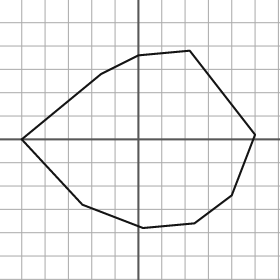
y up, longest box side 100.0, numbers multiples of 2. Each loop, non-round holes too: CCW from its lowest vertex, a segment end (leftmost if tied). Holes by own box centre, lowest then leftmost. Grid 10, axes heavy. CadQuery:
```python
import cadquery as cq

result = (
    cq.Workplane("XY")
    .moveTo(2.0, -38.0)
    .lineTo(24.0, -36.0)
    .lineTo(40.0, -24.0)
    .lineTo(50.0, 2.0)
    .lineTo(22.0, 38.0)
    .lineTo(0.0, 36.0)
    .lineTo(-16.0, 28.0)
    .lineTo(-50.0, 0.0)
    .lineTo(-24.0, -28.0)
    .close()
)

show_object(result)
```